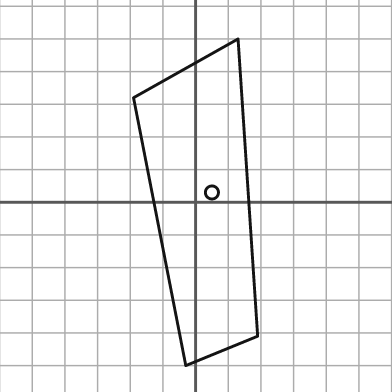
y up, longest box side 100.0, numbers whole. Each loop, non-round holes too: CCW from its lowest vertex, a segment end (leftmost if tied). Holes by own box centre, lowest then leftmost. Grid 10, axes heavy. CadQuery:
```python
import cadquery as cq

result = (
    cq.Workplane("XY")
    .moveTo(-3.0, -50.0)
    .lineTo(19.0, -41.0)
    .lineTo(13.0, 50.0)
    .lineTo(-19.0, 32.0)
    .close()
    .moveTo(5.0, 3.0)
    .circle(2.0)
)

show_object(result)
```